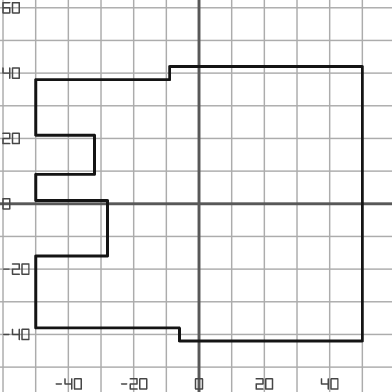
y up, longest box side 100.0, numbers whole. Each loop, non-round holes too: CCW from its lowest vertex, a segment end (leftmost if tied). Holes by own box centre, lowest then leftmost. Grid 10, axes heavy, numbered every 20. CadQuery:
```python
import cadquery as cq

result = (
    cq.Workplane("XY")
    .moveTo(-6.0, -42.0)
    .lineTo(50.0, -42.0)
    .lineTo(50.0, 42.0)
    .lineTo(-9.0, 42.0)
    .lineTo(-9.0, 38.0)
    .lineTo(-50.0, 38.0)
    .lineTo(-50.0, 21.0)
    .lineTo(-32.0, 21.0)
    .lineTo(-32.0, 9.0)
    .lineTo(-50.0, 9.0)
    .lineTo(-50.0, 1.0)
    .lineTo(-28.0, 1.0)
    .lineTo(-28.0, -16.0)
    .lineTo(-50.0, -16.0)
    .lineTo(-50.0, -38.0)
    .lineTo(-6.0, -38.0)
    .close()
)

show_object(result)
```